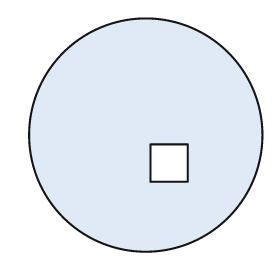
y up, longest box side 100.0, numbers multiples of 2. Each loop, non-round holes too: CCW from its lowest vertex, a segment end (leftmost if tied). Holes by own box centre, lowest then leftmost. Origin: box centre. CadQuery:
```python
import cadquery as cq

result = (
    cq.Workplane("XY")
    .moveTo(0.0, 0.0)
    .circle(50.0)
    .moveTo(2.0, -20.0)
    .lineTo(18.0, -20.0)
    .lineTo(18.0, -4.0)
    .lineTo(2.0, -4.0)
    .close()
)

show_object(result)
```